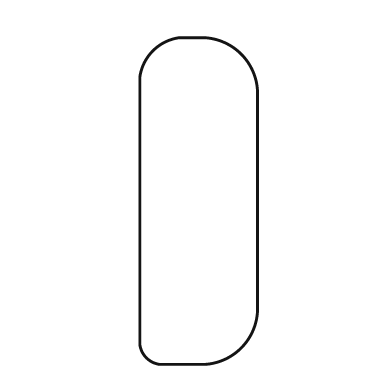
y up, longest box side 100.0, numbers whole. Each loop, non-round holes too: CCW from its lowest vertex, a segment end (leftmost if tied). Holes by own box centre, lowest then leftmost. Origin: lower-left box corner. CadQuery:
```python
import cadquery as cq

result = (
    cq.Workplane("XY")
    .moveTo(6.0, 0.0)
    .lineTo(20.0, 0.0)
    .threePointArc((31.0, 5.0), (36.0, 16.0))
    .lineTo(36.0, 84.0)
    .threePointArc((31.0, 95.0), (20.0, 100.0))
    .lineTo(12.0, 100.0)
    .threePointArc((4.0, 96.0), (0.0, 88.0))
    .lineTo(0.0, 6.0)
    .threePointArc((2.0, 2.0), (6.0, 0.0))
    .close()
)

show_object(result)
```